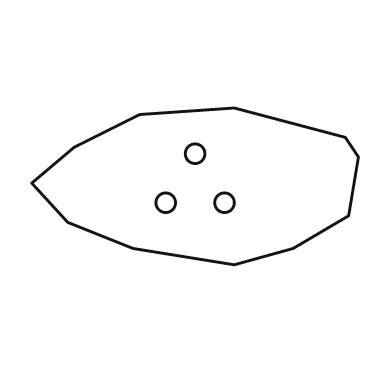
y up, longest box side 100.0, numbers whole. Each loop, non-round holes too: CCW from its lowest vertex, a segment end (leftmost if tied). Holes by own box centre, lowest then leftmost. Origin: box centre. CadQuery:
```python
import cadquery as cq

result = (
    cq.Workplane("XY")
    .moveTo(12.0, -24.0)
    .lineTo(30.0, -19.0)
    .lineTo(47.0, -9.0)
    .lineTo(50.0, 9.0)
    .lineTo(46.0, 15.0)
    .lineTo(12.0, 24.0)
    .lineTo(-17.0, 22.0)
    .lineTo(-37.0, 12.0)
    .lineTo(-50.0, 1.0)
    .lineTo(-39.0, -11.0)
    .lineTo(-19.0, -19.0)
    .close()
    .moveTo(-9.0, -5.0)
    .circle(3.0)
    .moveTo(9.0, -5.0)
    .circle(3.0)
    .moveTo(0.0, 10.0)
    .circle(3.0)
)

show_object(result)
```